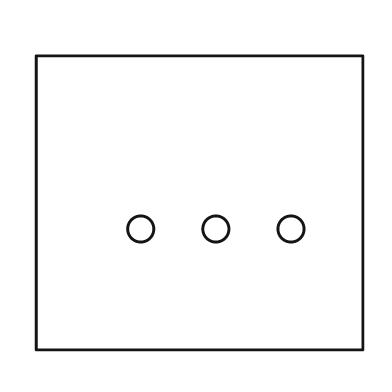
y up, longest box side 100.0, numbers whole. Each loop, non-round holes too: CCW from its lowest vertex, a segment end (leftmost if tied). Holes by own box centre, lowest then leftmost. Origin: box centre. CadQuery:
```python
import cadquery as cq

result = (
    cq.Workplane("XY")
    .moveTo(-50.0, -45.0)
    .lineTo(50.0, -45.0)
    .lineTo(50.0, 45.0)
    .lineTo(-50.0, 45.0)
    .close()
    .moveTo(-18.0, -8.0)
    .circle(4.0)
    .moveTo(5.0, -8.0)
    .circle(4.0)
    .moveTo(28.0, -8.0)
    .circle(4.0)
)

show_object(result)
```